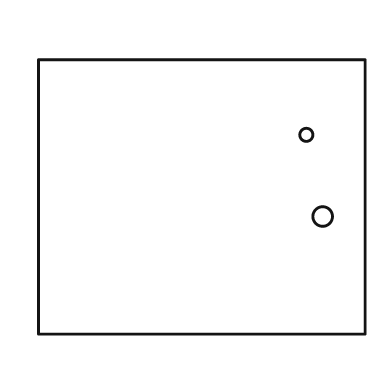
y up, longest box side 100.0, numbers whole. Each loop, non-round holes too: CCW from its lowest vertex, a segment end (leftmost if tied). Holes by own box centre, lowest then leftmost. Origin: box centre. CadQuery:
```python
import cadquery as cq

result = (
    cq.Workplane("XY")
    .moveTo(-50.0, -42.0)
    .lineTo(50.0, -42.0)
    .lineTo(50.0, 42.0)
    .lineTo(-50.0, 42.0)
    .close()
    .moveTo(37.0, -6.0)
    .circle(3.0)
    .moveTo(32.0, 19.0)
    .circle(2.0)
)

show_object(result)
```